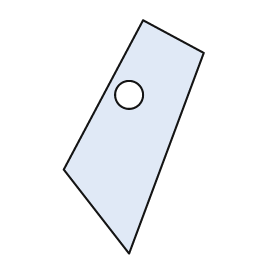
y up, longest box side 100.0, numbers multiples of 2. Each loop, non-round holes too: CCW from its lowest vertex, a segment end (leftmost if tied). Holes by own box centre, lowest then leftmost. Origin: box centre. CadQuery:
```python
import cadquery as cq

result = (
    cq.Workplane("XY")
    .moveTo(-2.0, -50.0)
    .lineTo(30.0, 36.0)
    .lineTo(4.0, 50.0)
    .lineTo(-30.0, -14.0)
    .close()
    .moveTo(-2.0, 18.0)
    .circle(6.0)
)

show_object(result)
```